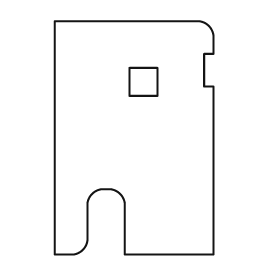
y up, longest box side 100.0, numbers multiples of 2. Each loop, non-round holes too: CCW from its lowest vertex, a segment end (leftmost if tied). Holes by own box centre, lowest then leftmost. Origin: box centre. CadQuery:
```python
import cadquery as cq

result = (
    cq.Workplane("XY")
    .moveTo(-34.0, -50.0)
    .lineTo(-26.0, -50.0)
    .threePointArc((-22.0, -48.0), (-20.0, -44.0))
    .lineTo(-20.0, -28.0)
    .threePointArc((-18.0, -24.0), (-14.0, -22.0))
    .lineTo(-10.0, -22.0)
    .threePointArc((-6.0, -24.0), (-4.0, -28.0))
    .lineTo(-4.0, -50.0)
    .lineTo(34.0, -50.0)
    .lineTo(34.0, 22.0)
    .lineTo(30.0, 22.0)
    .lineTo(30.0, 36.0)
    .lineTo(34.0, 36.0)
    .lineTo(34.0, 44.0)
    .threePointArc((32.0, 48.0), (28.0, 50.0))
    .lineTo(-34.0, 50.0)
    .close()
    .moveTo(-2.0, 18.0)
    .lineTo(10.0, 18.0)
    .lineTo(10.0, 30.0)
    .lineTo(-2.0, 30.0)
    .close()
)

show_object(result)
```